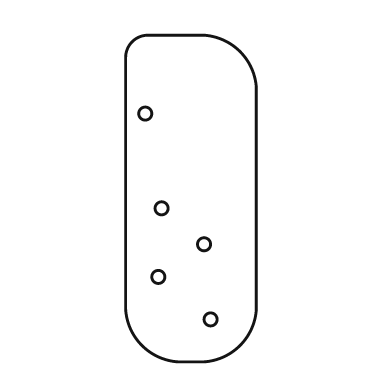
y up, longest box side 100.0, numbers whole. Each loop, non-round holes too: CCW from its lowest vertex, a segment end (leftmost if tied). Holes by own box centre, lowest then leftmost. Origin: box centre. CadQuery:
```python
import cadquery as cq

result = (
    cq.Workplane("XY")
    .moveTo(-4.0, -50.0)
    .lineTo(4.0, -50.0)
    .threePointArc((15.0, -45.0), (20.0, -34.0))
    .lineTo(20.0, 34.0)
    .threePointArc((15.0, 45.0), (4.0, 50.0))
    .lineTo(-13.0, 50.0)
    .threePointArc((-18.0, 48.0), (-20.0, 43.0))
    .lineTo(-20.0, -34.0)
    .threePointArc((-15.0, -45.0), (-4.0, -50.0))
    .close()
    .moveTo(6.0, -37.0)
    .circle(2.0)
    .moveTo(-10.0, -24.0)
    .circle(2.0)
    .moveTo(4.0, -14.0)
    .circle(2.0)
    .moveTo(-9.0, -3.0)
    .circle(2.0)
    .moveTo(-14.0, 26.0)
    .circle(2.0)
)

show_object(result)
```